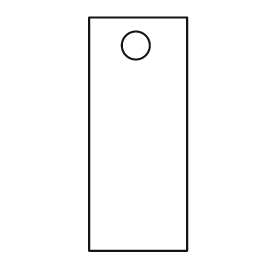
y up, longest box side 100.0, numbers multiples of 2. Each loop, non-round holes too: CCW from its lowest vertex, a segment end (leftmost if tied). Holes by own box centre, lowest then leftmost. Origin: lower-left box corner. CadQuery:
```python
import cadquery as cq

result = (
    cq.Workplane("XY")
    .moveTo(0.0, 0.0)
    .lineTo(42.0, 0.0)
    .lineTo(42.0, 100.0)
    .lineTo(0.0, 100.0)
    .close()
    .moveTo(20.0, 88.0)
    .circle(6.0)
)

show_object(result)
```